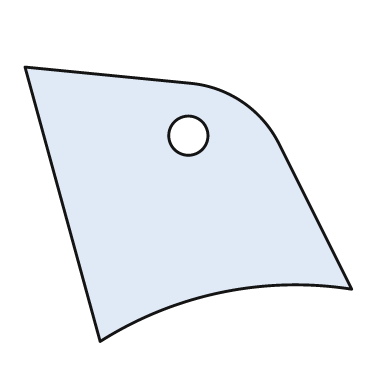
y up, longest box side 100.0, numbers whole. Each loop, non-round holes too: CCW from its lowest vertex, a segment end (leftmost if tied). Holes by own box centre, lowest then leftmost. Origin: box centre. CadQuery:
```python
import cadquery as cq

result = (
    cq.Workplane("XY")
    .moveTo(-27.0, -42.0)
    .threePointArc((10.0, -27.0), (50.0, -26.0))
    .lineTo(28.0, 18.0)
    .threePointArc((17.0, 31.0), (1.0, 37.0))
    .lineTo(-50.0, 42.0)
    .close()
    .moveTo(0.0, 21.0)
    .circle(6.0)
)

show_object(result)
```